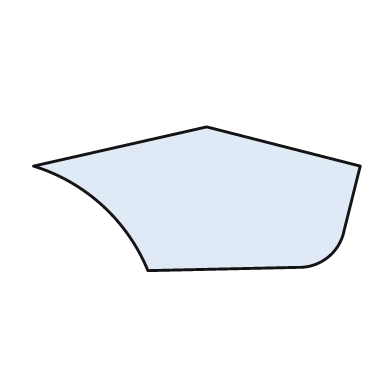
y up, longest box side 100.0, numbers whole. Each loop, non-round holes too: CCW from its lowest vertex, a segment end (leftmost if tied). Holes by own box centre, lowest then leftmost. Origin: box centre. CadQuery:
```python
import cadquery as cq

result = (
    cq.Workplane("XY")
    .moveTo(-15.0, -22.0)
    .lineTo(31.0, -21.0)
    .threePointArc((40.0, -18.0), (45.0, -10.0))
    .lineTo(50.0, 10.0)
    .lineTo(3.0, 22.0)
    .lineTo(-50.0, 10.0)
    .threePointArc((-29.0, -2.0), (-15.0, -22.0))
    .close()
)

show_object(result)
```